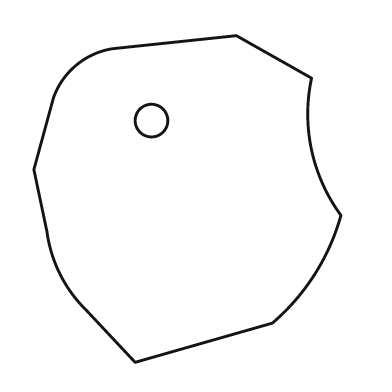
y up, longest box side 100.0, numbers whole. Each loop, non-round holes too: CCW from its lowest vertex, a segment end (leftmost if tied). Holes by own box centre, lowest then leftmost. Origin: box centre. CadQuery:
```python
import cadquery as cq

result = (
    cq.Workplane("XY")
    .moveTo(-16.0, -50.0)
    .lineTo(26.0, -38.0)
    .threePointArc((39.0, -23.0), (47.0, -5.0))
    .threePointArc((38.0, 15.0), (38.0, 37.0))
    .lineTo(15.0, 50.0)
    .lineTo(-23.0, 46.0)
    .threePointArc((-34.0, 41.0), (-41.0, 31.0))
    .lineTo(-47.0, 9.0)
    .lineTo(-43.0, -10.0)
    .threePointArc((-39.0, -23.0), (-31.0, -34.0))
    .close()
    .moveTo(-11.0, 24.0)
    .circle(5.0)
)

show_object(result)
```